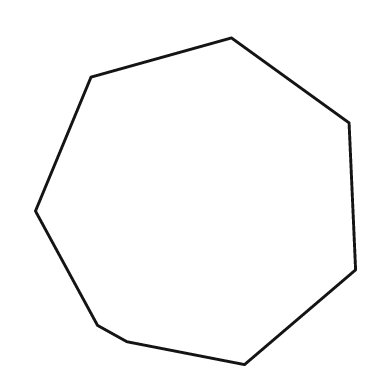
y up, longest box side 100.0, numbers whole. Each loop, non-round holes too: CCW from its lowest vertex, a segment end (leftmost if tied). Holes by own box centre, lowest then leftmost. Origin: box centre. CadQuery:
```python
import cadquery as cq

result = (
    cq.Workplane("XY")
    .moveTo(15.0, -50.0)
    .lineTo(49.0, -21.0)
    .lineTo(47.0, 24.0)
    .lineTo(11.0, 50.0)
    .lineTo(-32.0, 38.0)
    .lineTo(-49.0, -3.0)
    .lineTo(-30.0, -38.0)
    .lineTo(-21.0, -43.0)
    .close()
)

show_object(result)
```